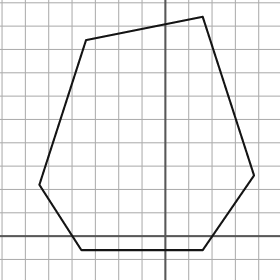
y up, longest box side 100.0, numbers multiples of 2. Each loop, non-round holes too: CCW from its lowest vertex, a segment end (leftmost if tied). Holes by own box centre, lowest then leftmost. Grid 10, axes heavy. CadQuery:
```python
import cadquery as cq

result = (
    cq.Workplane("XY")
    .moveTo(-36.0, -6.0)
    .lineTo(16.0, -6.0)
    .lineTo(38.0, 26.0)
    .lineTo(16.0, 94.0)
    .lineTo(-34.0, 84.0)
    .lineTo(-54.0, 22.0)
    .close()
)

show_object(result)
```